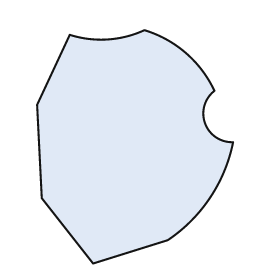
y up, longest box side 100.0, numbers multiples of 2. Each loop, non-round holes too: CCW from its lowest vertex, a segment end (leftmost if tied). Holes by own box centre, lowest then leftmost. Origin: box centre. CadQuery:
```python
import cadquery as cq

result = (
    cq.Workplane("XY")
    .moveTo(-18.0, -50.0)
    .lineTo(14.0, -40.0)
    .threePointArc((32.0, -22.0), (42.0, 2.0))
    .threePointArc((30.0, 10.0), (34.0, 24.0))
    .threePointArc((22.0, 40.0), (4.0, 50.0))
    .threePointArc((-12.0, 46.0), (-28.0, 48.0))
    .lineTo(-42.0, 18.0)
    .lineTo(-40.0, -22.0)
    .close()
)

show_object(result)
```